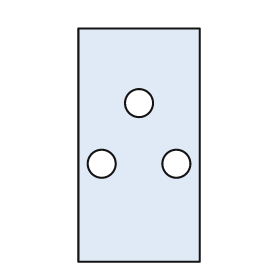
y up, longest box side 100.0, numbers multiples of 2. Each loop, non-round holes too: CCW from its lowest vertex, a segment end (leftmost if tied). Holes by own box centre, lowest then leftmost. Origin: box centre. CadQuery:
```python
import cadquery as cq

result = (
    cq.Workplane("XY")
    .moveTo(-26.0, -50.0)
    .lineTo(26.0, -50.0)
    .lineTo(26.0, 50.0)
    .lineTo(-26.0, 50.0)
    .close()
    .moveTo(-16.0, -8.0)
    .circle(6.0)
    .moveTo(16.0, -8.0)
    .circle(6.0)
    .moveTo(0.0, 18.0)
    .circle(6.0)
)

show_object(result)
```